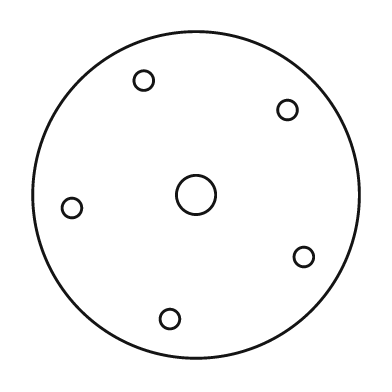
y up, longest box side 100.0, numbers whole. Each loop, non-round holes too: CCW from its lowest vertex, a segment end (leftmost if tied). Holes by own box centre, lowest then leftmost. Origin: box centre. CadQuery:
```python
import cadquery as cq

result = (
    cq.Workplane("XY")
    .moveTo(0.0, 0.0)
    .circle(50.0)
    .moveTo(-8.0, -38.0)
    .circle(3.0)
    .moveTo(33.0, -19.0)
    .circle(3.0)
    .moveTo(-38.0, -4.0)
    .circle(3.0)
    .moveTo(0.0, 0.0)
    .circle(6.0)
    .moveTo(28.0, 26.0)
    .circle(3.0)
    .moveTo(-16.0, 35.0)
    .circle(3.0)
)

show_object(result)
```